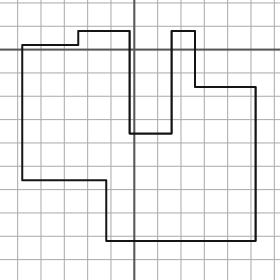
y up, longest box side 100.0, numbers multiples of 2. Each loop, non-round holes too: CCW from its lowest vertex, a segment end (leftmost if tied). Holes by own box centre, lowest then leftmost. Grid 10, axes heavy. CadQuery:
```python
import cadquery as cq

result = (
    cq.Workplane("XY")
    .moveTo(-12.0, -82.0)
    .lineTo(52.0, -82.0)
    .lineTo(52.0, -16.0)
    .lineTo(26.0, -16.0)
    .lineTo(26.0, 8.0)
    .lineTo(16.0, 8.0)
    .lineTo(16.0, -36.0)
    .lineTo(-2.0, -36.0)
    .lineTo(-2.0, 8.0)
    .lineTo(-24.0, 8.0)
    .lineTo(-24.0, 2.0)
    .lineTo(-48.0, 2.0)
    .lineTo(-48.0, -56.0)
    .lineTo(-12.0, -56.0)
    .close()
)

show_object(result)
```